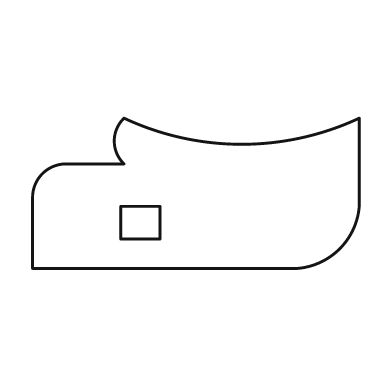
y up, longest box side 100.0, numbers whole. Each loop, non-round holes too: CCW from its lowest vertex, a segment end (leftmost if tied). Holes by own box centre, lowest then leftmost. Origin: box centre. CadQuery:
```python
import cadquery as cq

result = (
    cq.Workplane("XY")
    .moveTo(-50.0, -23.0)
    .lineTo(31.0, -23.0)
    .threePointArc((44.0, -17.0), (50.0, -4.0))
    .lineTo(50.0, 23.0)
    .threePointArc((14.0, 15.0), (-22.0, 23.0))
    .threePointArc((-25.0, 16.0), (-22.0, 9.0))
    .lineTo(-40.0, 9.0)
    .threePointArc((-47.0, 6.0), (-50.0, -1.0))
    .close()
    .moveTo(-23.0, -14.0)
    .lineTo(-11.0, -14.0)
    .lineTo(-11.0, -4.0)
    .lineTo(-23.0, -4.0)
    .close()
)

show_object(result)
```